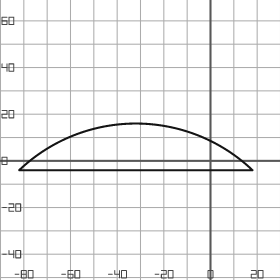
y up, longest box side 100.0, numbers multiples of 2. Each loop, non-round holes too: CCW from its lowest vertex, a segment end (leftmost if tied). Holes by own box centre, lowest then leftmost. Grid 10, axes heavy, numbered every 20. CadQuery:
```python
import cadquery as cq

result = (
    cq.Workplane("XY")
    .moveTo(-82.0, -4.0)
    .lineTo(18.0, -4.0)
    .threePointArc((-32.0, 16.0), (-82.0, -4.0))
    .close()
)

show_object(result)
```